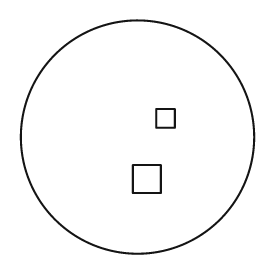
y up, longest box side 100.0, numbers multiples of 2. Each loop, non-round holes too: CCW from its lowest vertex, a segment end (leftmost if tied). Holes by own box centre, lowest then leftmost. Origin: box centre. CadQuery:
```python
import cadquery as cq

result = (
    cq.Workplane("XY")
    .moveTo(0.0, 0.0)
    .circle(50.0)
    .moveTo(-2.0, -24.0)
    .lineTo(10.0, -24.0)
    .lineTo(10.0, -12.0)
    .lineTo(-2.0, -12.0)
    .close()
    .moveTo(8.0, 4.0)
    .lineTo(16.0, 4.0)
    .lineTo(16.0, 12.0)
    .lineTo(8.0, 12.0)
    .close()
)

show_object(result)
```